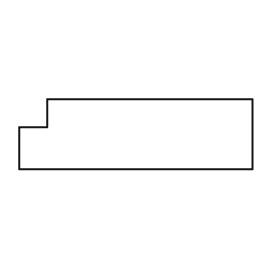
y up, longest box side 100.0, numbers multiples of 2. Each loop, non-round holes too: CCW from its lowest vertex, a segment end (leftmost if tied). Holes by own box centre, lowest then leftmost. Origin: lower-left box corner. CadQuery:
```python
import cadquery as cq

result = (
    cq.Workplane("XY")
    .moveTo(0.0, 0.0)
    .lineTo(100.0, 0.0)
    .lineTo(100.0, 30.0)
    .lineTo(12.0, 30.0)
    .lineTo(12.0, 18.0)
    .lineTo(0.0, 18.0)
    .close()
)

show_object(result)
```